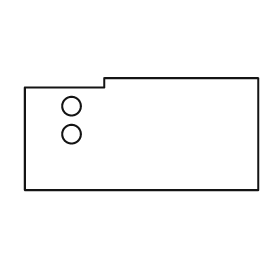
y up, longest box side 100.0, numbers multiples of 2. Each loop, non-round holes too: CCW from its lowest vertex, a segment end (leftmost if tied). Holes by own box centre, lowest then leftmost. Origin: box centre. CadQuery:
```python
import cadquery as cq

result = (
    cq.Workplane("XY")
    .moveTo(-50.0, -24.0)
    .lineTo(50.0, -24.0)
    .lineTo(50.0, 24.0)
    .lineTo(-16.0, 24.0)
    .lineTo(-16.0, 20.0)
    .lineTo(-50.0, 20.0)
    .close()
    .moveTo(-30.0, 0.0)
    .circle(4.0)
    .moveTo(-30.0, 12.0)
    .circle(4.0)
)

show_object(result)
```